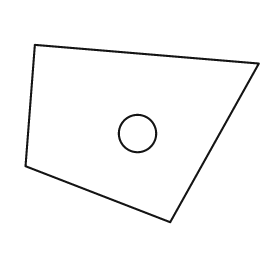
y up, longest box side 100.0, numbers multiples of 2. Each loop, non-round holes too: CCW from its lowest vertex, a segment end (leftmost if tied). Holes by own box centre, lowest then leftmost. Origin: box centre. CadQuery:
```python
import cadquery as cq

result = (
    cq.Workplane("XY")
    .moveTo(12.0, -38.0)
    .lineTo(50.0, 30.0)
    .lineTo(-46.0, 38.0)
    .lineTo(-50.0, -14.0)
    .close()
    .moveTo(-2.0, 0.0)
    .circle(8.0)
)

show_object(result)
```